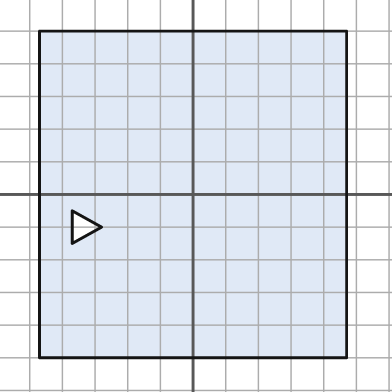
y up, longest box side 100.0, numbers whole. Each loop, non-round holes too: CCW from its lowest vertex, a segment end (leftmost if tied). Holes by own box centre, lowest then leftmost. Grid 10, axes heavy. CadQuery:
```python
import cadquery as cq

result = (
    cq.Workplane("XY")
    .moveTo(-47.0, -50.0)
    .lineTo(47.0, -50.0)
    .lineTo(47.0, 50.0)
    .lineTo(-47.0, 50.0)
    .close()
    .moveTo(-37.0, -15.0)
    .lineTo(-28.0, -10.0)
    .lineTo(-37.0, -5.0)
    .close()
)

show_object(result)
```